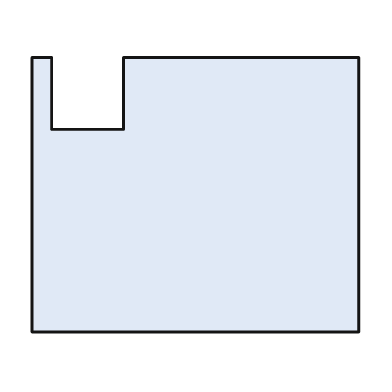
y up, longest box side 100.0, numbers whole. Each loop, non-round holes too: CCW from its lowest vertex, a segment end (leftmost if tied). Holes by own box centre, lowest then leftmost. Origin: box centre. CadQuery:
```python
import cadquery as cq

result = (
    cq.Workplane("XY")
    .moveTo(-50.0, -42.0)
    .lineTo(50.0, -42.0)
    .lineTo(50.0, 42.0)
    .lineTo(-22.0, 42.0)
    .lineTo(-22.0, 20.0)
    .lineTo(-44.0, 20.0)
    .lineTo(-44.0, 42.0)
    .lineTo(-50.0, 42.0)
    .close()
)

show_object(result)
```